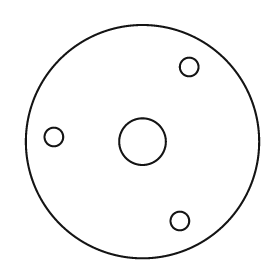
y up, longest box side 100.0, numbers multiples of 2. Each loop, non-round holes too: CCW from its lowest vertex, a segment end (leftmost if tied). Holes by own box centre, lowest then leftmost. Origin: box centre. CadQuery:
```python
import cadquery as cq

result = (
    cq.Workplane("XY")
    .moveTo(0.0, 0.0)
    .circle(50.0)
    .moveTo(16.0, -34.0)
    .circle(4.0)
    .moveTo(0.0, 0.0)
    .circle(10.0)
    .moveTo(-38.0, 2.0)
    .circle(4.0)
    .moveTo(20.0, 32.0)
    .circle(4.0)
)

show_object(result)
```